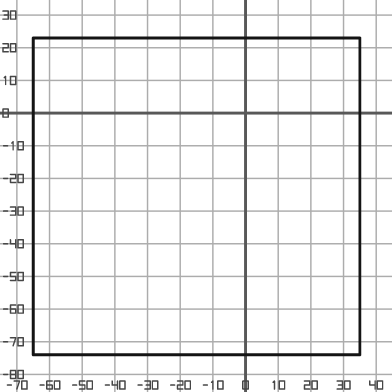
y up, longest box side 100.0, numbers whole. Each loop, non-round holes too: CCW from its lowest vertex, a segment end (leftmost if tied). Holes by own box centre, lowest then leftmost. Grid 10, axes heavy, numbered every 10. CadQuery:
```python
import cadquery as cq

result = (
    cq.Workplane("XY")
    .moveTo(-65.0, -74.0)
    .lineTo(35.0, -74.0)
    .lineTo(35.0, 23.0)
    .lineTo(-65.0, 23.0)
    .close()
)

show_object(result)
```